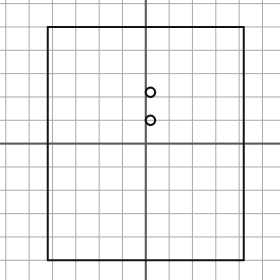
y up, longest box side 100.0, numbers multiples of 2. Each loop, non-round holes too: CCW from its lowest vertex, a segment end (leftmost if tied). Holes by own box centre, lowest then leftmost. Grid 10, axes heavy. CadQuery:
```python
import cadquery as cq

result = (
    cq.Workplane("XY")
    .moveTo(-42.0, -50.0)
    .lineTo(42.0, -50.0)
    .lineTo(42.0, 50.0)
    .lineTo(-42.0, 50.0)
    .close()
    .moveTo(2.0, 10.0)
    .circle(2.0)
    .moveTo(2.0, 22.0)
    .circle(2.0)
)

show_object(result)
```